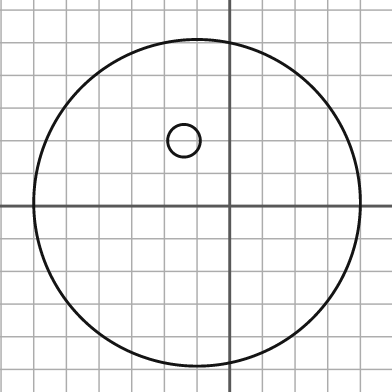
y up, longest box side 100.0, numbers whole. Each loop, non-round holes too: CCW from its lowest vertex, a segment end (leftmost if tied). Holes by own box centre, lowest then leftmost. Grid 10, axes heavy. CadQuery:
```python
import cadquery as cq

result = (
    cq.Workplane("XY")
    .moveTo(-10.0, 1.0)
    .circle(50.0)
    .moveTo(-14.0, 20.0)
    .circle(5.0)
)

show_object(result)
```